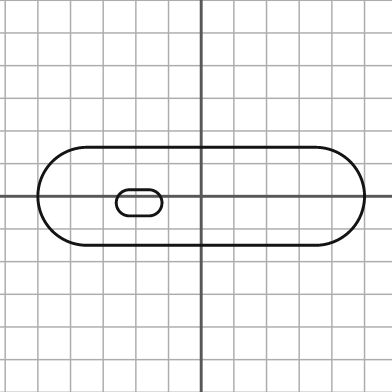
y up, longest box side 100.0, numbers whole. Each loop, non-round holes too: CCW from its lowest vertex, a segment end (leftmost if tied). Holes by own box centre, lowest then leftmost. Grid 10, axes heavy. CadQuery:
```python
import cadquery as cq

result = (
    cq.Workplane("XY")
    .moveTo(-35.0, -15.0)
    .lineTo(35.0, -15.0)
    .threePointArc((50.0, 0.0), (35.0, 15.0))
    .lineTo(-35.0, 15.0)
    .threePointArc((-50.0, 0.0), (-35.0, -15.0))
    .close()
    .moveTo(-22.0, -6.0)
    .lineTo(-16.0, -6.0)
    .threePointArc((-12.0, -2.0), (-16.0, 2.0))
    .lineTo(-22.0, 2.0)
    .threePointArc((-26.0, -2.0), (-22.0, -6.0))
    .close()
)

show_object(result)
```